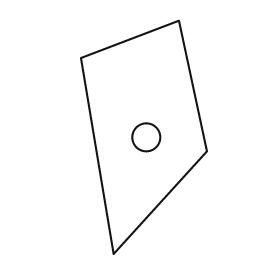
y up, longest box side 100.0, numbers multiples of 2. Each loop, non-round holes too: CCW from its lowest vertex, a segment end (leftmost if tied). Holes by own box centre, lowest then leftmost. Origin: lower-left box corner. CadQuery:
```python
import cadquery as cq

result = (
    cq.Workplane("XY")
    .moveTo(14.0, 0.0)
    .lineTo(54.0, 44.0)
    .lineTo(42.0, 100.0)
    .lineTo(0.0, 84.0)
    .close()
    .moveTo(28.0, 50.0)
    .circle(6.0)
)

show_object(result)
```